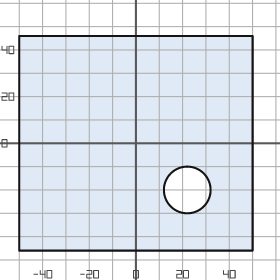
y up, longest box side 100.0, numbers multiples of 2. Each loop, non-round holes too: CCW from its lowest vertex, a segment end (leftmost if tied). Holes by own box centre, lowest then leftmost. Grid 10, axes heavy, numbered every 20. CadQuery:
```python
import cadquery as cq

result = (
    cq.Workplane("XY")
    .moveTo(-50.0, -46.0)
    .lineTo(50.0, -46.0)
    .lineTo(50.0, 46.0)
    .lineTo(-50.0, 46.0)
    .close()
    .moveTo(22.0, -20.0)
    .circle(10.0)
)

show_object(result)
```